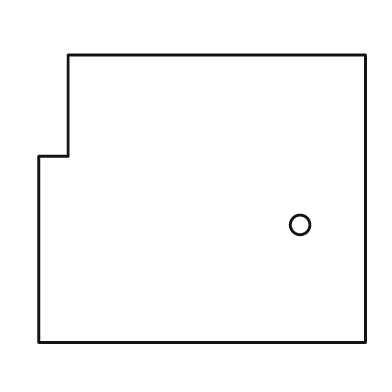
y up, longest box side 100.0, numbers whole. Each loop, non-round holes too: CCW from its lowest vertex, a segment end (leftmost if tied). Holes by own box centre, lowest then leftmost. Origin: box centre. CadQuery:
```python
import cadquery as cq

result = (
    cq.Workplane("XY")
    .moveTo(-50.0, -44.0)
    .lineTo(50.0, -44.0)
    .lineTo(50.0, 44.0)
    .lineTo(-41.0, 44.0)
    .lineTo(-41.0, 13.0)
    .lineTo(-50.0, 13.0)
    .close()
    .moveTo(30.0, -8.0)
    .circle(3.0)
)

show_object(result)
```